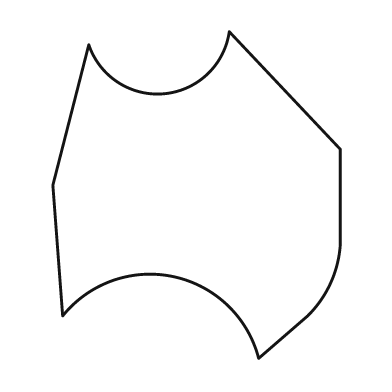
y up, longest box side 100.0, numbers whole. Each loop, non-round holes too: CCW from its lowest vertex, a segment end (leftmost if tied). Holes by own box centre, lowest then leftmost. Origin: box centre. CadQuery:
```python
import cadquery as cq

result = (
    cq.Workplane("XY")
    .moveTo(19.0, -50.0)
    .lineTo(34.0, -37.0)
    .threePointArc((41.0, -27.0), (44.0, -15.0))
    .lineTo(44.0, 14.0)
    .lineTo(10.0, 50.0)
    .threePointArc((-10.0, 31.0), (-33.0, 46.0))
    .lineTo(-44.0, 3.0)
    .lineTo(-41.0, -37.0)
    .threePointArc((-7.0, -25.0), (19.0, -50.0))
    .close()
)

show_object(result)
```